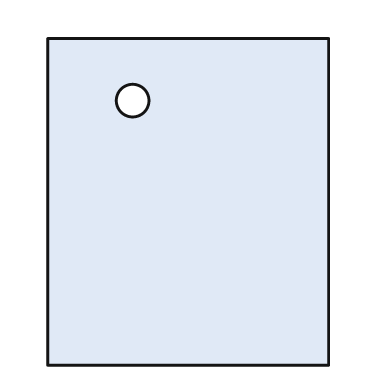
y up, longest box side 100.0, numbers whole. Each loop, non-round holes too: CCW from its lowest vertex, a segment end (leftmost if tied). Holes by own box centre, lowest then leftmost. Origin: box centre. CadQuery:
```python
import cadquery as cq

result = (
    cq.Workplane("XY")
    .moveTo(-43.0, -50.0)
    .lineTo(43.0, -50.0)
    .lineTo(43.0, 50.0)
    .lineTo(-43.0, 50.0)
    .close()
    .moveTo(-17.0, 31.0)
    .circle(5.0)
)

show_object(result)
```